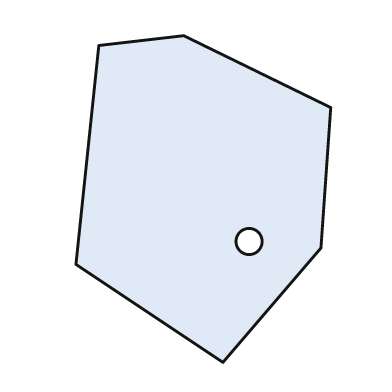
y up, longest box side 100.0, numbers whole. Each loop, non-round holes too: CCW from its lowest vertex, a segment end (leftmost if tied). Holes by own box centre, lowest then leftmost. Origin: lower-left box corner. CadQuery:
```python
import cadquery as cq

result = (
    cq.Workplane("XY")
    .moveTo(45.0, 0.0)
    .lineTo(75.0, 35.0)
    .lineTo(78.0, 78.0)
    .lineTo(33.0, 100.0)
    .lineTo(7.0, 97.0)
    .lineTo(0.0, 30.0)
    .close()
    .moveTo(53.0, 37.0)
    .circle(4.0)
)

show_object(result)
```